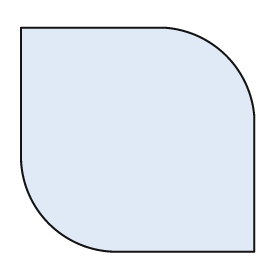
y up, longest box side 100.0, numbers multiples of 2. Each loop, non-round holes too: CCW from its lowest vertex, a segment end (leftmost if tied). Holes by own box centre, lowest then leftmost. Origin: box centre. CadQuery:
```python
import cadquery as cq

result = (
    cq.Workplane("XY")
    .moveTo(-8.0, -48.0)
    .lineTo(50.0, -48.0)
    .lineTo(50.0, 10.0)
    .threePointArc((38.0, 36.0), (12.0, 48.0))
    .lineTo(-50.0, 48.0)
    .lineTo(-50.0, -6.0)
    .threePointArc((-38.0, -36.0), (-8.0, -48.0))
    .close()
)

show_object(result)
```